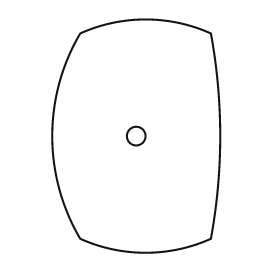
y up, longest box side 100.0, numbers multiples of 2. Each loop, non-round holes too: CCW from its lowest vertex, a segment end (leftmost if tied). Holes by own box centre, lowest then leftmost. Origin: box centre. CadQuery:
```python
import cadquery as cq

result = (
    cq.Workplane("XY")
    .moveTo(-24.0, -44.0)
    .threePointArc((4.0, -50.0), (32.0, -44.0))
    .threePointArc((36.0, 0.0), (32.0, 44.0))
    .threePointArc((4.0, 50.0), (-24.0, 44.0))
    .threePointArc((-36.0, 0.0), (-24.0, -44.0))
    .close()
    .moveTo(0.0, 0.0)
    .circle(4.0)
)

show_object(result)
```